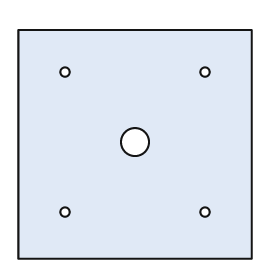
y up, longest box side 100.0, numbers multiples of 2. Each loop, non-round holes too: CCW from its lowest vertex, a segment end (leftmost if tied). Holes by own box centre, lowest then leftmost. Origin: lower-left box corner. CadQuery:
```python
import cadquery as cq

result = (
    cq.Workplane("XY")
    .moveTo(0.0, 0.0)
    .lineTo(100.0, 0.0)
    .lineTo(100.0, 98.0)
    .lineTo(0.0, 98.0)
    .close()
    .moveTo(20.0, 20.0)
    .circle(2.0)
    .moveTo(80.0, 20.0)
    .circle(2.0)
    .moveTo(50.0, 50.0)
    .circle(6.0)
    .moveTo(20.0, 80.0)
    .circle(2.0)
    .moveTo(80.0, 80.0)
    .circle(2.0)
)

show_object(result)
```